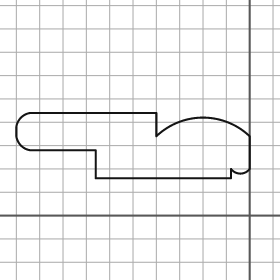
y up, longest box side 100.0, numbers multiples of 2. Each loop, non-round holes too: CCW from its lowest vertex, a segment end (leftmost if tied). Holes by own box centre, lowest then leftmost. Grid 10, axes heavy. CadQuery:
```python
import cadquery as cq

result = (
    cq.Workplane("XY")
    .moveTo(-66.0, 16.0)
    .lineTo(-8.0, 16.0)
    .lineTo(-8.0, 20.0)
    .threePointArc((-4.0, 18.0), (0.0, 20.0))
    .lineTo(0.0, 34.0)
    .threePointArc((-20.0, 42.0), (-40.0, 34.0))
    .lineTo(-40.0, 44.0)
    .lineTo(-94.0, 44.0)
    .threePointArc((-98.0, 42.0), (-100.0, 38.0))
    .lineTo(-100.0, 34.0)
    .threePointArc((-98.0, 30.0), (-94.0, 28.0))
    .lineTo(-66.0, 28.0)
    .close()
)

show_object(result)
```